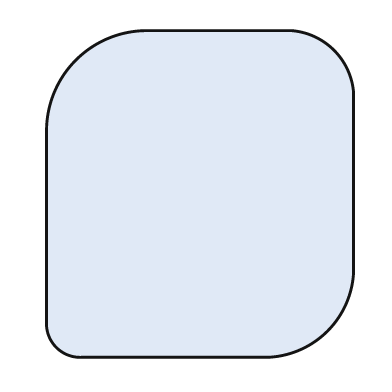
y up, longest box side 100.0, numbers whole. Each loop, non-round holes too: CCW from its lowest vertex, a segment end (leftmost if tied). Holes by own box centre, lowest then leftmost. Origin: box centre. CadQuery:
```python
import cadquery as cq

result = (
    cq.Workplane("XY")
    .moveTo(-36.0, -50.0)
    .lineTo(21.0, -50.0)
    .threePointArc((39.0, -42.0), (47.0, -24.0))
    .lineTo(47.0, 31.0)
    .threePointArc((41.0, 44.0), (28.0, 50.0))
    .lineTo(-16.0, 50.0)
    .threePointArc((-38.0, 41.0), (-47.0, 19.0))
    .lineTo(-47.0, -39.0)
    .threePointArc((-44.0, -47.0), (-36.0, -50.0))
    .close()
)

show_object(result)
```